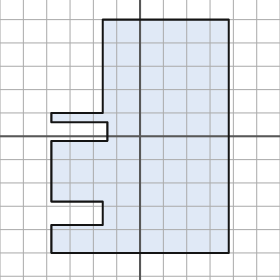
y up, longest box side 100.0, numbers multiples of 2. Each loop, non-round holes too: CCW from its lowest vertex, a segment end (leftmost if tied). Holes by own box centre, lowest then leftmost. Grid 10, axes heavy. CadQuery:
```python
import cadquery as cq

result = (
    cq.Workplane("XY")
    .moveTo(-38.0, -50.0)
    .lineTo(38.0, -50.0)
    .lineTo(38.0, 50.0)
    .lineTo(-16.0, 50.0)
    .lineTo(-16.0, 10.0)
    .lineTo(-38.0, 10.0)
    .lineTo(-38.0, 6.0)
    .lineTo(-14.0, 6.0)
    .lineTo(-14.0, -2.0)
    .lineTo(-38.0, -2.0)
    .lineTo(-38.0, -28.0)
    .lineTo(-16.0, -28.0)
    .lineTo(-16.0, -38.0)
    .lineTo(-38.0, -38.0)
    .close()
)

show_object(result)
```